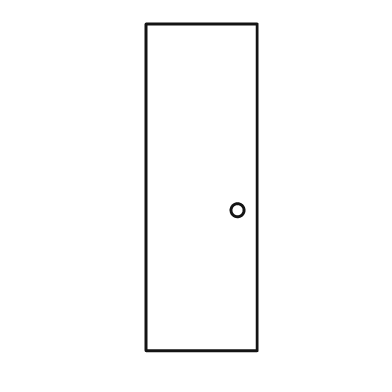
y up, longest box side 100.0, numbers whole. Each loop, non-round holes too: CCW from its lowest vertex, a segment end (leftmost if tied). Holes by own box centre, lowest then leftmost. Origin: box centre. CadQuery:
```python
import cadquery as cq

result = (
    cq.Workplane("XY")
    .moveTo(-17.0, -50.0)
    .lineTo(17.0, -50.0)
    .lineTo(17.0, 50.0)
    .lineTo(-17.0, 50.0)
    .close()
    .moveTo(11.0, -7.0)
    .circle(2.0)
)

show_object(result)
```